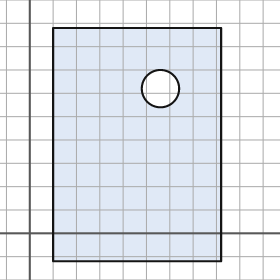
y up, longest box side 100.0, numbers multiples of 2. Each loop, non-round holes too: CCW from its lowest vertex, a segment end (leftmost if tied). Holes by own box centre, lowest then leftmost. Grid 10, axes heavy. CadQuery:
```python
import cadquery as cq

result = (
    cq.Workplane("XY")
    .moveTo(10.0, -12.0)
    .lineTo(82.0, -12.0)
    .lineTo(82.0, 88.0)
    .lineTo(10.0, 88.0)
    .close()
    .moveTo(56.0, 62.0)
    .circle(8.0)
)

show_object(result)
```